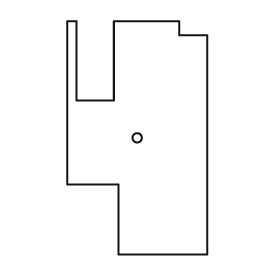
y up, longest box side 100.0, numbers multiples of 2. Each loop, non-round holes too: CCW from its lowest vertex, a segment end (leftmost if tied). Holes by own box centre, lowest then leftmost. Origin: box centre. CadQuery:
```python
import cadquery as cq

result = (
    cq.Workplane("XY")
    .moveTo(-8.0, -50.0)
    .lineTo(30.0, -50.0)
    .lineTo(30.0, 44.0)
    .lineTo(18.0, 44.0)
    .lineTo(18.0, 50.0)
    .lineTo(-10.0, 50.0)
    .lineTo(-10.0, 16.0)
    .lineTo(-26.0, 16.0)
    .lineTo(-26.0, 50.0)
    .lineTo(-30.0, 50.0)
    .lineTo(-30.0, -20.0)
    .lineTo(-8.0, -20.0)
    .close()
    .moveTo(0.0, 0.0)
    .circle(2.0)
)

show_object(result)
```